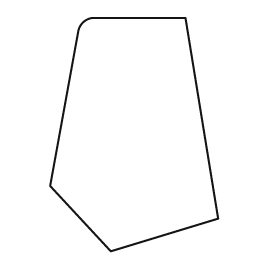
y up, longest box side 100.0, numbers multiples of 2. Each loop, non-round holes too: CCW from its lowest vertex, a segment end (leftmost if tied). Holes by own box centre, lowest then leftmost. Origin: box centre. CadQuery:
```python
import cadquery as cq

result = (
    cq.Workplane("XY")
    .moveTo(-10.0, -50.0)
    .lineTo(36.0, -36.0)
    .lineTo(22.0, 50.0)
    .lineTo(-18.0, 50.0)
    .threePointArc((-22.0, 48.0), (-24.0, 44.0))
    .lineTo(-36.0, -22.0)
    .close()
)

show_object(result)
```